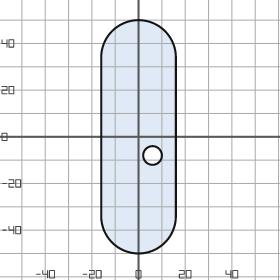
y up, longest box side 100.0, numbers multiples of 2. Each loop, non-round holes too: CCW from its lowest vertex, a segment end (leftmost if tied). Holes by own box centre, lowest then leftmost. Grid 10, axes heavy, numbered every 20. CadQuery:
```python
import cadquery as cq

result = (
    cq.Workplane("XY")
    .moveTo(-16.0, -34.0)
    .threePointArc((0.0, -50.0), (16.0, -34.0))
    .lineTo(16.0, 34.0)
    .threePointArc((0.0, 50.0), (-16.0, 34.0))
    .close()
    .moveTo(6.0, -8.0)
    .circle(4.0)
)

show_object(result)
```